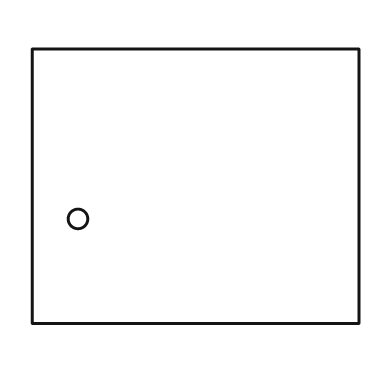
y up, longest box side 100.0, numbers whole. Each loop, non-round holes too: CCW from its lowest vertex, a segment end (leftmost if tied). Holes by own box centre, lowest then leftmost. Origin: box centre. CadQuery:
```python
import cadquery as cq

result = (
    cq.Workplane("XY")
    .moveTo(-50.0, -42.0)
    .lineTo(50.0, -42.0)
    .lineTo(50.0, 42.0)
    .lineTo(-50.0, 42.0)
    .close()
    .moveTo(-36.0, -10.0)
    .circle(3.0)
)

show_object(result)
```